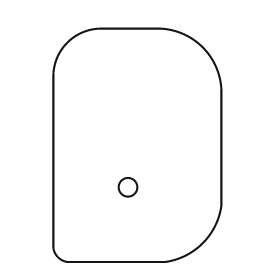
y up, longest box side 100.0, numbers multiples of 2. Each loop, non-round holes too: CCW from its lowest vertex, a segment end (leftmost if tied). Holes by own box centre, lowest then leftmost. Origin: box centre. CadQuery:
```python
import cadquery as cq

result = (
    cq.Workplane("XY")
    .moveTo(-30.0, -50.0)
    .lineTo(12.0, -50.0)
    .threePointArc((28.0, -42.0), (36.0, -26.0))
    .lineTo(36.0, 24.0)
    .threePointArc((28.0, 42.0), (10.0, 50.0))
    .lineTo(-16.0, 50.0)
    .threePointArc((-30.0, 44.0), (-36.0, 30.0))
    .lineTo(-36.0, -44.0)
    .threePointArc((-34.0, -48.0), (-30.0, -50.0))
    .close()
    .moveTo(-4.0, -18.0)
    .circle(4.0)
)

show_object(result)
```